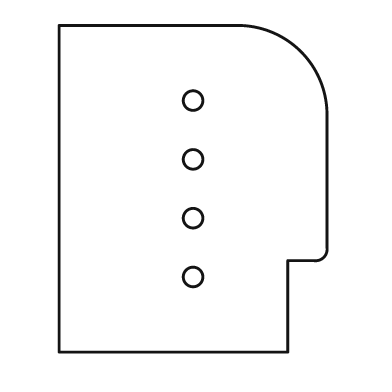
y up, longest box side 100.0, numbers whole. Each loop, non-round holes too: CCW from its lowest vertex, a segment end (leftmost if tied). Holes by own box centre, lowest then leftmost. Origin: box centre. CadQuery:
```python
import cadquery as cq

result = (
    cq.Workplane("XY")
    .moveTo(-41.0, -50.0)
    .lineTo(29.0, -50.0)
    .lineTo(29.0, -22.0)
    .lineTo(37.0, -22.0)
    .threePointArc((40.0, -21.0), (41.0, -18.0))
    .lineTo(41.0, 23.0)
    .threePointArc((33.0, 42.0), (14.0, 50.0))
    .lineTo(-41.0, 50.0)
    .close()
    .moveTo(0.0, -27.0)
    .circle(3.0)
    .moveTo(0.0, -9.0)
    .circle(3.0)
    .moveTo(0.0, 9.0)
    .circle(3.0)
    .moveTo(0.0, 27.0)
    .circle(3.0)
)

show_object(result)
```